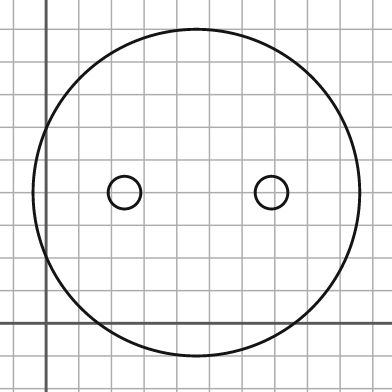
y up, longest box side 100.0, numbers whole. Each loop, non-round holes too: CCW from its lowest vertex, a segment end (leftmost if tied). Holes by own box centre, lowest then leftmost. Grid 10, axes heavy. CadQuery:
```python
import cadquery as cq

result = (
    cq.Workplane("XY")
    .moveTo(46.0, 40.0)
    .circle(50.0)
    .moveTo(24.0, 40.0)
    .circle(5.0)
    .moveTo(69.0, 40.0)
    .circle(5.0)
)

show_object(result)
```